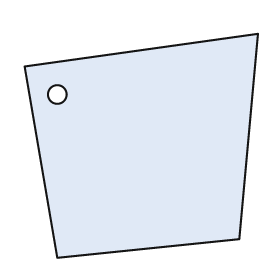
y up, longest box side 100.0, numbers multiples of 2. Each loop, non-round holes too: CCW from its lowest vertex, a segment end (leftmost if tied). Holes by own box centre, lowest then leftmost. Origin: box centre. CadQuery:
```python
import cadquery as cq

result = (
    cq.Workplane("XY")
    .moveTo(-36.0, -48.0)
    .lineTo(42.0, -40.0)
    .lineTo(50.0, 48.0)
    .lineTo(-50.0, 34.0)
    .close()
    .moveTo(-36.0, 22.0)
    .circle(4.0)
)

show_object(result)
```